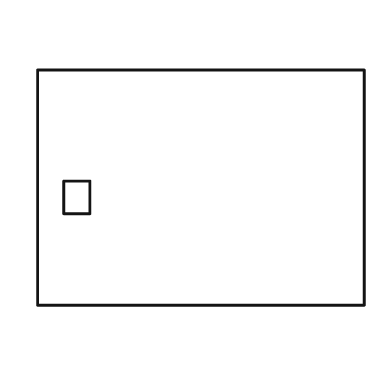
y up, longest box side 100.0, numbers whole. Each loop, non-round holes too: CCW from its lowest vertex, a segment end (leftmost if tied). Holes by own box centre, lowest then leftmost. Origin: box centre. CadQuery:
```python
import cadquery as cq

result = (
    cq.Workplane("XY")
    .moveTo(-50.0, -36.0)
    .lineTo(50.0, -36.0)
    .lineTo(50.0, 36.0)
    .lineTo(-50.0, 36.0)
    .close()
    .moveTo(-42.0, -8.0)
    .lineTo(-34.0, -8.0)
    .lineTo(-34.0, 2.0)
    .lineTo(-42.0, 2.0)
    .close()
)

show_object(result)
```